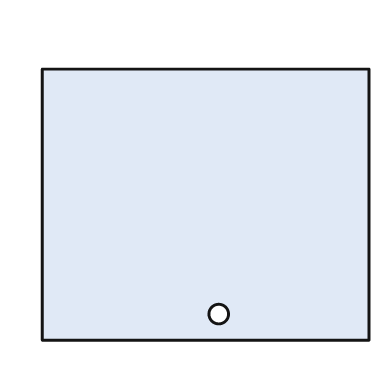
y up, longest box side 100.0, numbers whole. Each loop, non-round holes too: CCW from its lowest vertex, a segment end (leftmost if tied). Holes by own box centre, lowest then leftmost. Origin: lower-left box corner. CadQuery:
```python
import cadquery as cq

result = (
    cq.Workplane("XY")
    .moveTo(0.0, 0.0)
    .lineTo(100.0, 0.0)
    .lineTo(100.0, 83.0)
    .lineTo(0.0, 83.0)
    .close()
    .moveTo(54.0, 8.0)
    .circle(3.0)
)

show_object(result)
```